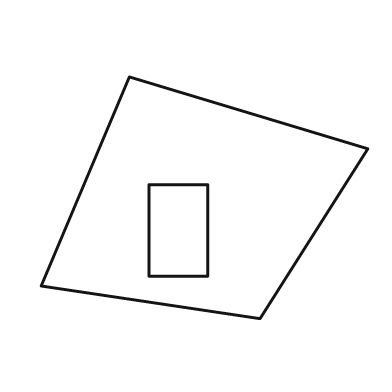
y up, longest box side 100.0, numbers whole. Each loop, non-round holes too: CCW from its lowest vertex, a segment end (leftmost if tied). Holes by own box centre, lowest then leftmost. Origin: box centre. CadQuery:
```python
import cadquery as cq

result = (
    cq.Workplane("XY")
    .moveTo(17.0, -37.0)
    .lineTo(50.0, 15.0)
    .lineTo(-23.0, 37.0)
    .lineTo(-50.0, -27.0)
    .close()
    .moveTo(-17.0, -24.0)
    .lineTo(1.0, -24.0)
    .lineTo(1.0, 4.0)
    .lineTo(-17.0, 4.0)
    .close()
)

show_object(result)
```